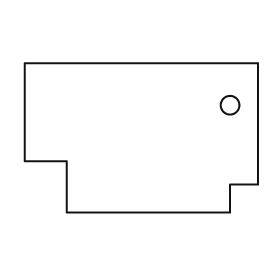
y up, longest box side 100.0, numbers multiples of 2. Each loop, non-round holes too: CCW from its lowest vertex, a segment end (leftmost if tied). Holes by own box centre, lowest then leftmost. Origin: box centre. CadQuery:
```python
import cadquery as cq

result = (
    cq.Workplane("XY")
    .moveTo(-32.0, -32.0)
    .lineTo(38.0, -32.0)
    .lineTo(38.0, -20.0)
    .lineTo(50.0, -20.0)
    .lineTo(50.0, 32.0)
    .lineTo(-50.0, 32.0)
    .lineTo(-50.0, -10.0)
    .lineTo(-32.0, -10.0)
    .close()
    .moveTo(38.0, 14.0)
    .circle(4.0)
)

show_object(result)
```